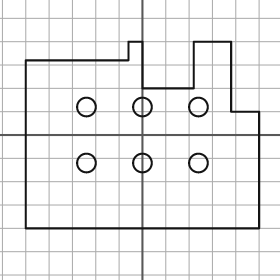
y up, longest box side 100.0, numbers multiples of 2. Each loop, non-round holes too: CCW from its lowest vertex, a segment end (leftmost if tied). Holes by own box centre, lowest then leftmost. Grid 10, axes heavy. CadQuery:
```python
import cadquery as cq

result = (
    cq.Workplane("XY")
    .moveTo(-50.0, -40.0)
    .lineTo(50.0, -40.0)
    .lineTo(50.0, 10.0)
    .lineTo(38.0, 10.0)
    .lineTo(38.0, 40.0)
    .lineTo(22.0, 40.0)
    .lineTo(22.0, 20.0)
    .lineTo(0.0, 20.0)
    .lineTo(0.0, 40.0)
    .lineTo(-6.0, 40.0)
    .lineTo(-6.0, 32.0)
    .lineTo(-50.0, 32.0)
    .close()
    .moveTo(-24.0, -12.0)
    .circle(4.0)
    .moveTo(0.0, -12.0)
    .circle(4.0)
    .moveTo(24.0, -12.0)
    .circle(4.0)
    .moveTo(-24.0, 12.0)
    .circle(4.0)
    .moveTo(0.0, 12.0)
    .circle(4.0)
    .moveTo(24.0, 12.0)
    .circle(4.0)
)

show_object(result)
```